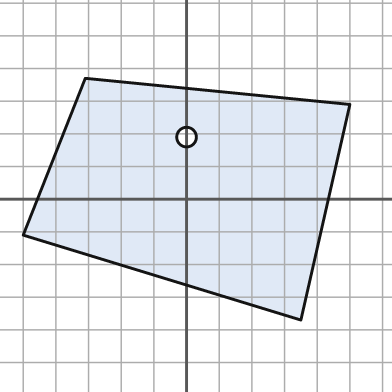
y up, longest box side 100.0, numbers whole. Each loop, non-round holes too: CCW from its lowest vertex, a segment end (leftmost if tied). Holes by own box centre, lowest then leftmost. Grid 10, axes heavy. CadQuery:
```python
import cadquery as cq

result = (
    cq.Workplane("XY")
    .moveTo(35.0, -37.0)
    .lineTo(50.0, 29.0)
    .lineTo(-31.0, 37.0)
    .lineTo(-50.0, -11.0)
    .close()
    .moveTo(0.0, 19.0)
    .circle(3.0)
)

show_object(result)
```